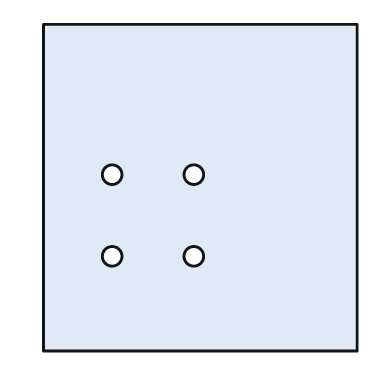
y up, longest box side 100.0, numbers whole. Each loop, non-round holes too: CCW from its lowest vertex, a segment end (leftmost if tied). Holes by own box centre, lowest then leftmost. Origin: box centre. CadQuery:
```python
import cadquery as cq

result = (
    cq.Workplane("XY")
    .moveTo(-48.0, -50.0)
    .lineTo(48.0, -50.0)
    .lineTo(48.0, 50.0)
    .lineTo(-48.0, 50.0)
    .close()
    .moveTo(-27.0, -21.0)
    .circle(3.0)
    .moveTo(-2.0, -21.0)
    .circle(3.0)
    .moveTo(-27.0, 4.0)
    .circle(3.0)
    .moveTo(-2.0, 4.0)
    .circle(3.0)
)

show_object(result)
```